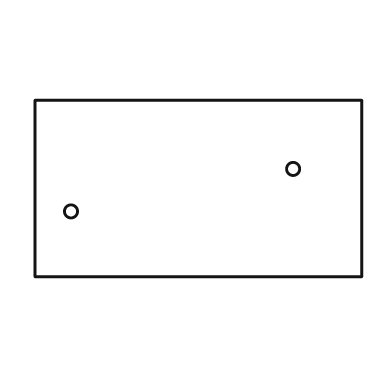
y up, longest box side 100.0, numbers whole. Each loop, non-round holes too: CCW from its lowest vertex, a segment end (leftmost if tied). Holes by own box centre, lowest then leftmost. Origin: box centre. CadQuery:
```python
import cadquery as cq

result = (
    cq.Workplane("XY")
    .moveTo(-50.0, -27.0)
    .lineTo(50.0, -27.0)
    .lineTo(50.0, 27.0)
    .lineTo(-50.0, 27.0)
    .close()
    .moveTo(-39.0, -7.0)
    .circle(2.0)
    .moveTo(29.0, 6.0)
    .circle(2.0)
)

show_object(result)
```